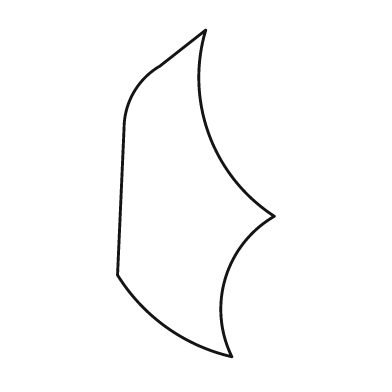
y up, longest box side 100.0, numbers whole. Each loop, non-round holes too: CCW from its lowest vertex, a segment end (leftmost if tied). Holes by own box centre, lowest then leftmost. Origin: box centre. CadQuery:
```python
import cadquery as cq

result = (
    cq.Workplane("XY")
    .moveTo(11.0, -50.0)
    .threePointArc((9.0, -26.0), (24.0, -7.0))
    .threePointArc((4.0, 18.0), (3.0, 50.0))
    .lineTo(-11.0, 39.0)
    .threePointArc((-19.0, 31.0), (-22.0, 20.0))
    .lineTo(-24.0, -25.0)
    .threePointArc((-9.0, -41.0), (11.0, -50.0))
    .close()
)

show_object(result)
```